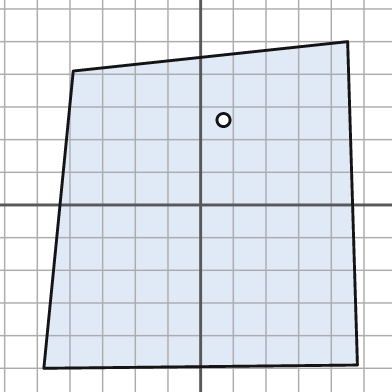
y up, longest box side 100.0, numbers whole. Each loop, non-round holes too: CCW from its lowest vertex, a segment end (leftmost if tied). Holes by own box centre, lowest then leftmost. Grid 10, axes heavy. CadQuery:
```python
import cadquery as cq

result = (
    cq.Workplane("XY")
    .moveTo(-48.0, -50.0)
    .lineTo(48.0, -49.0)
    .lineTo(45.0, 50.0)
    .lineTo(-39.0, 41.0)
    .close()
    .moveTo(7.0, 26.0)
    .circle(2.0)
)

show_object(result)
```